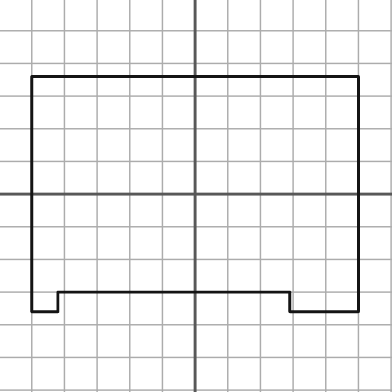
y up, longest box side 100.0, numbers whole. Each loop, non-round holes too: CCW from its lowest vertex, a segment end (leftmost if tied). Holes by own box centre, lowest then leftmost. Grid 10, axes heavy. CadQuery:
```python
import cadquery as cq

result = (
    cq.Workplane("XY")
    .moveTo(-50.0, -36.0)
    .lineTo(-42.0, -36.0)
    .lineTo(-42.0, -30.0)
    .lineTo(29.0, -30.0)
    .lineTo(29.0, -36.0)
    .lineTo(50.0, -36.0)
    .lineTo(50.0, 36.0)
    .lineTo(-50.0, 36.0)
    .close()
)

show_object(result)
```